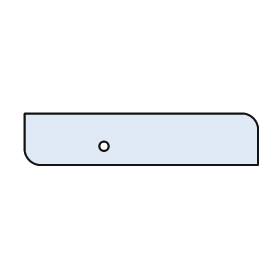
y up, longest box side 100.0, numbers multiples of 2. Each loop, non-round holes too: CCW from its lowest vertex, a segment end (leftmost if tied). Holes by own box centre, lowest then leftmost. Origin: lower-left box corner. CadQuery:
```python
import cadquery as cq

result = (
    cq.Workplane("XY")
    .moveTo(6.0, 0.0)
    .lineTo(100.0, 0.0)
    .lineTo(100.0, 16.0)
    .threePointArc((98.0, 20.0), (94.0, 22.0))
    .lineTo(0.0, 22.0)
    .lineTo(0.0, 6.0)
    .threePointArc((2.0, 2.0), (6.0, 0.0))
    .close()
    .moveTo(34.0, 8.0)
    .circle(2.0)
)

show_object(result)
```